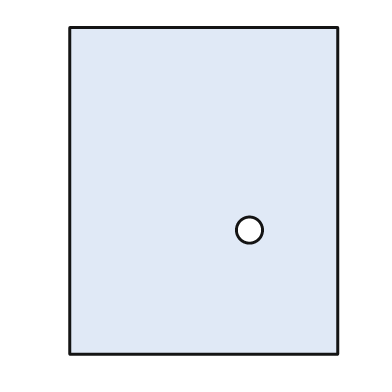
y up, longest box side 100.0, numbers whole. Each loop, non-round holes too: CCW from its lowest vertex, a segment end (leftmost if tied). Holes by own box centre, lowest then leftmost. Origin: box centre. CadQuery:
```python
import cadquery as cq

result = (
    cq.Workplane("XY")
    .moveTo(-41.0, -50.0)
    .lineTo(41.0, -50.0)
    .lineTo(41.0, 50.0)
    .lineTo(-41.0, 50.0)
    .close()
    .moveTo(14.0, -12.0)
    .circle(4.0)
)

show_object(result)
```